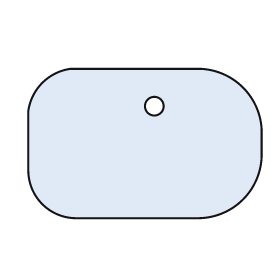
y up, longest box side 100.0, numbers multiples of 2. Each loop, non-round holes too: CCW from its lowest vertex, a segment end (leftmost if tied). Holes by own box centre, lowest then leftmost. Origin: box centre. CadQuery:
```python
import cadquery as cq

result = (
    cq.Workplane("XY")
    .moveTo(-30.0, -32.0)
    .lineTo(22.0, -32.0)
    .threePointArc((42.0, -24.0), (50.0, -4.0))
    .lineTo(50.0, 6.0)
    .threePointArc((42.0, 24.0), (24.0, 32.0))
    .lineTo(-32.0, 32.0)
    .threePointArc((-44.0, 26.0), (-50.0, 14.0))
    .lineTo(-50.0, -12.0)
    .threePointArc((-44.0, -26.0), (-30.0, -32.0))
    .close()
    .moveTo(4.0, 16.0)
    .circle(4.0)
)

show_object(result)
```